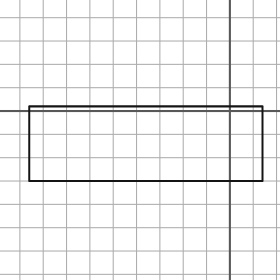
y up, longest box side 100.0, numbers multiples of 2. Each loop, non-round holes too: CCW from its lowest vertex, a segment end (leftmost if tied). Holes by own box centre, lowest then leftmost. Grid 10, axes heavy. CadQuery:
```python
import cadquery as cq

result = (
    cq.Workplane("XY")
    .moveTo(-86.0, -30.0)
    .lineTo(14.0, -30.0)
    .lineTo(14.0, 2.0)
    .lineTo(-86.0, 2.0)
    .close()
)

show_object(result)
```